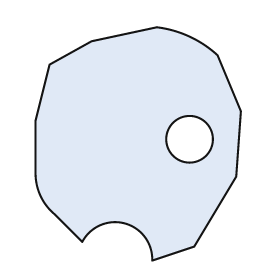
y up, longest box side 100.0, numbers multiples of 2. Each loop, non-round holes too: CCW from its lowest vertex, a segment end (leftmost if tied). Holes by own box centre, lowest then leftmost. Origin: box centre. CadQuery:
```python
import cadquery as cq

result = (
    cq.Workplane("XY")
    .moveTo(6.0, -50.0)
    .lineTo(24.0, -44.0)
    .lineTo(42.0, -14.0)
    .lineTo(44.0, 14.0)
    .lineTo(34.0, 38.0)
    .threePointArc((22.0, 46.0), (8.0, 50.0))
    .lineTo(-20.0, 44.0)
    .lineTo(-38.0, 34.0)
    .lineTo(-44.0, 10.0)
    .lineTo(-44.0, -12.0)
    .threePointArc((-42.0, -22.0), (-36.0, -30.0))
    .lineTo(-24.0, -42.0)
    .threePointArc((-6.0, -34.0), (6.0, -50.0))
    .close()
    .moveTo(22.0, 2.0)
    .circle(10.0)
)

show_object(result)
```